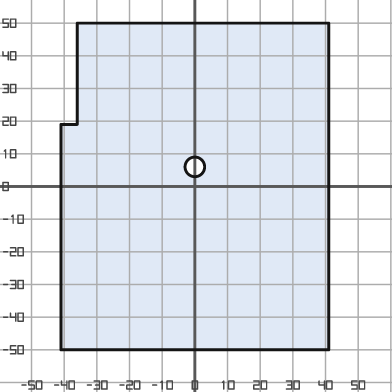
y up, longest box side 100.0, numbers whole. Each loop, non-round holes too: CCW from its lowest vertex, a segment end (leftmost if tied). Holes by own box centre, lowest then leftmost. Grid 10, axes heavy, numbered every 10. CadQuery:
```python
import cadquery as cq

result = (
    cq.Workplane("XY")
    .moveTo(-41.0, -50.0)
    .lineTo(41.0, -50.0)
    .lineTo(41.0, 50.0)
    .lineTo(-36.0, 50.0)
    .lineTo(-36.0, 19.0)
    .lineTo(-41.0, 19.0)
    .close()
    .moveTo(0.0, 6.0)
    .circle(3.0)
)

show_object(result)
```